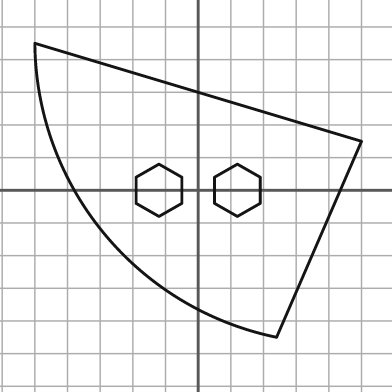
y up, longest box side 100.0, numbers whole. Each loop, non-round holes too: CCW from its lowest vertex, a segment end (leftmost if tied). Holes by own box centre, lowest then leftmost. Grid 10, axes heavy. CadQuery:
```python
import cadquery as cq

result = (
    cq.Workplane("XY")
    .moveTo(24.0, -45.0)
    .lineTo(50.0, 15.0)
    .lineTo(-50.0, 45.0)
    .threePointArc((-29.0, -13.0), (24.0, -45.0))
    .close()
    .moveTo(-12.0, -8.0)
    .lineTo(-5.0, -4.0)
    .lineTo(-5.0, 4.0)
    .lineTo(-12.0, 8.0)
    .lineTo(-19.0, 4.0)
    .lineTo(-19.0, -4.0)
    .close()
    .moveTo(12.0, -8.0)
    .lineTo(19.0, -4.0)
    .lineTo(19.0, 4.0)
    .lineTo(12.0, 8.0)
    .lineTo(5.0, 4.0)
    .lineTo(5.0, -4.0)
    .close()
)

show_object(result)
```